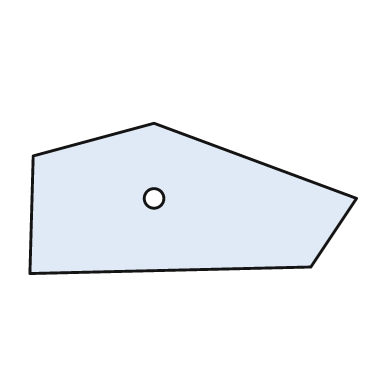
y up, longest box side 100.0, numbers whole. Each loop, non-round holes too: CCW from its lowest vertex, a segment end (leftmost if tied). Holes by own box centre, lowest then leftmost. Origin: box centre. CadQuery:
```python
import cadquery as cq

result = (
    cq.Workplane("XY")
    .moveTo(-50.0, -23.0)
    .lineTo(36.0, -21.0)
    .lineTo(50.0, 0.0)
    .lineTo(-12.0, 23.0)
    .lineTo(-49.0, 13.0)
    .close()
    .moveTo(-12.0, 0.0)
    .circle(3.0)
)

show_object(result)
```